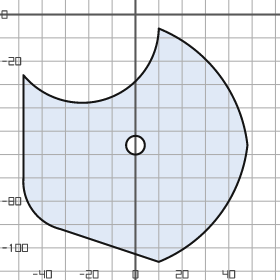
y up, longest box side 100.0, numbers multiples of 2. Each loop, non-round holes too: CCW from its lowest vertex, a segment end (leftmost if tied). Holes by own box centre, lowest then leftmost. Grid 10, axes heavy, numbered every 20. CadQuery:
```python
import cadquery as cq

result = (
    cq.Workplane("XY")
    .moveTo(10.0, -106.0)
    .threePointArc((36.0, -86.0), (48.0, -56.0))
    .threePointArc((36.0, -26.0), (10.0, -6.0))
    .threePointArc((-12.0, -36.0), (-48.0, -26.0))
    .lineTo(-48.0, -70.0)
    .threePointArc((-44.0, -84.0), (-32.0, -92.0))
    .close()
    .moveTo(0.0, -56.0)
    .circle(4.0)
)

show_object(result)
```